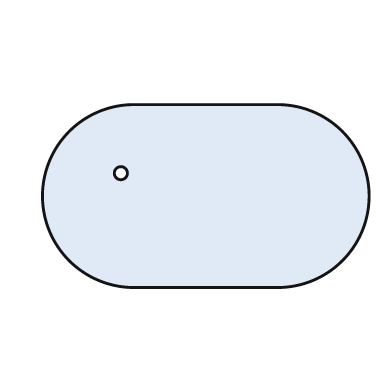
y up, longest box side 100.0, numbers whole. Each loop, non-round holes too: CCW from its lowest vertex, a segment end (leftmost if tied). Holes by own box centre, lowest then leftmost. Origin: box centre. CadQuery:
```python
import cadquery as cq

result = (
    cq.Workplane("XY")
    .moveTo(-22.0, -28.0)
    .lineTo(22.0, -28.0)
    .threePointArc((50.0, 0.0), (22.0, 28.0))
    .lineTo(-22.0, 28.0)
    .threePointArc((-50.0, 0.0), (-22.0, -28.0))
    .close()
    .moveTo(-26.0, 7.0)
    .circle(2.0)
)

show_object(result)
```